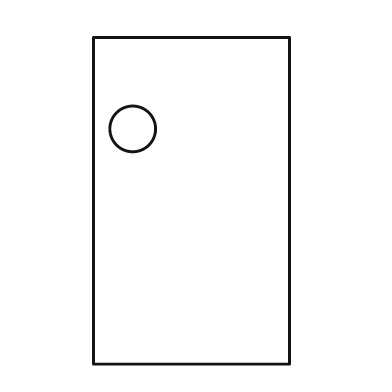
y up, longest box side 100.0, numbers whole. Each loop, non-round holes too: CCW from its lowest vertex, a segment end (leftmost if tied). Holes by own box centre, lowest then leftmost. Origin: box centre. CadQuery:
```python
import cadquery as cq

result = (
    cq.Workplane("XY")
    .moveTo(-30.0, -50.0)
    .lineTo(30.0, -50.0)
    .lineTo(30.0, 50.0)
    .lineTo(-30.0, 50.0)
    .close()
    .moveTo(-18.0, 22.0)
    .circle(7.0)
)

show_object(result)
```